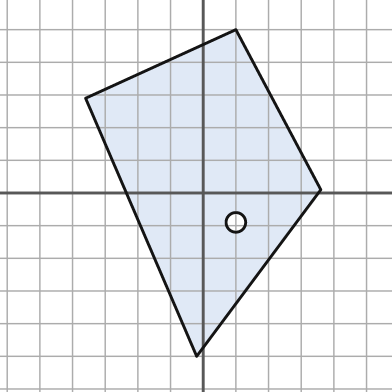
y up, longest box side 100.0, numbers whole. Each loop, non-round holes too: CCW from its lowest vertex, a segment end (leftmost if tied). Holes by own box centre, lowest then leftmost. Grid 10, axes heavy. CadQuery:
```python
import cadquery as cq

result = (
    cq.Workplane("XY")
    .moveTo(-2.0, -50.0)
    .lineTo(36.0, 1.0)
    .lineTo(10.0, 50.0)
    .lineTo(-36.0, 29.0)
    .close()
    .moveTo(10.0, -9.0)
    .circle(3.0)
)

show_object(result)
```